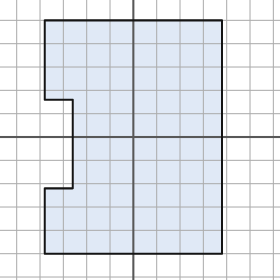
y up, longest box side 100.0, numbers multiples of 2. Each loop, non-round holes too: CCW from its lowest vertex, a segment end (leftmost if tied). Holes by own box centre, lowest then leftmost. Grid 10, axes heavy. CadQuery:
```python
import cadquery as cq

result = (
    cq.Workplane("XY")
    .moveTo(-38.0, -50.0)
    .lineTo(38.0, -50.0)
    .lineTo(38.0, 50.0)
    .lineTo(-38.0, 50.0)
    .lineTo(-38.0, 16.0)
    .lineTo(-26.0, 16.0)
    .lineTo(-26.0, -22.0)
    .lineTo(-38.0, -22.0)
    .close()
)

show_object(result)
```